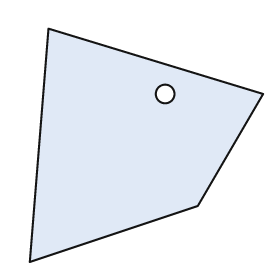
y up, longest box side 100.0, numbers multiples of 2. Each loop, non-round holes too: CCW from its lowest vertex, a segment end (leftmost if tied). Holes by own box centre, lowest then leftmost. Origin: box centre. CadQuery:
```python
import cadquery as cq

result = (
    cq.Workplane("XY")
    .moveTo(-50.0, -50.0)
    .lineTo(22.0, -26.0)
    .lineTo(50.0, 22.0)
    .lineTo(-42.0, 50.0)
    .close()
    .moveTo(8.0, 22.0)
    .circle(4.0)
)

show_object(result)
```